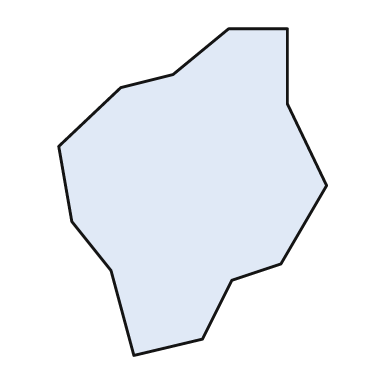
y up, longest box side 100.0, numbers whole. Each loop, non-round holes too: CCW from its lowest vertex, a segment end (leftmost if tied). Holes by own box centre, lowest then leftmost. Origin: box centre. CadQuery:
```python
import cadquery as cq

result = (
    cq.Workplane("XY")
    .moveTo(-18.0, -50.0)
    .lineTo(3.0, -45.0)
    .lineTo(12.0, -27.0)
    .lineTo(27.0, -22.0)
    .lineTo(41.0, 2.0)
    .lineTo(29.0, 27.0)
    .lineTo(29.0, 50.0)
    .lineTo(11.0, 50.0)
    .lineTo(-6.0, 36.0)
    .lineTo(-22.0, 32.0)
    .lineTo(-41.0, 14.0)
    .lineTo(-37.0, -9.0)
    .lineTo(-25.0, -24.0)
    .close()
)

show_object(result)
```